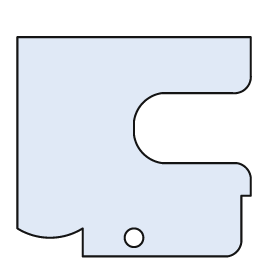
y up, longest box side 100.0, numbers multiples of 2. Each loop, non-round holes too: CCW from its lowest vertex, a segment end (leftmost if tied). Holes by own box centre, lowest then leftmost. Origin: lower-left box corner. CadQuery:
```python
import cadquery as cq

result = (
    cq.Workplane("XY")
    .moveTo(28.0, 0.0)
    .lineTo(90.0, 0.0)
    .threePointArc((94.0, 2.0), (96.0, 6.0))
    .lineTo(96.0, 26.0)
    .lineTo(100.0, 26.0)
    .lineTo(100.0, 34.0)
    .threePointArc((98.0, 38.0), (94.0, 40.0))
    .lineTo(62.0, 40.0)
    .threePointArc((54.0, 44.0), (50.0, 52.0))
    .lineTo(50.0, 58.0)
    .threePointArc((54.0, 66.0), (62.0, 70.0))
    .lineTo(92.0, 70.0)
    .threePointArc((98.0, 72.0), (100.0, 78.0))
    .lineTo(100.0, 94.0)
    .lineTo(0.0, 94.0)
    .lineTo(0.0, 12.0)
    .threePointArc((14.0, 8.0), (28.0, 12.0))
    .close()
    .moveTo(50.0, 8.0)
    .circle(4.0)
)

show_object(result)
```